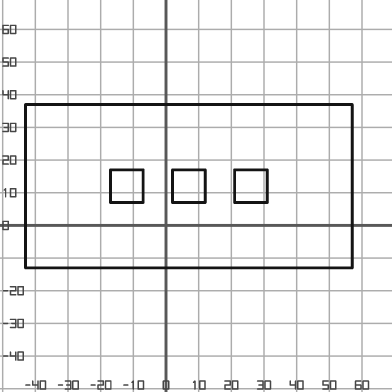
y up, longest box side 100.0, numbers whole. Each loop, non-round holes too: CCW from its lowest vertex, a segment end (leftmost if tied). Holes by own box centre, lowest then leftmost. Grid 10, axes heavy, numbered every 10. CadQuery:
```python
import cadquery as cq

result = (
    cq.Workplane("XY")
    .moveTo(-43.0, -13.0)
    .lineTo(57.0, -13.0)
    .lineTo(57.0, 37.0)
    .lineTo(-43.0, 37.0)
    .close()
    .moveTo(-17.0, 7.0)
    .lineTo(-7.0, 7.0)
    .lineTo(-7.0, 17.0)
    .lineTo(-17.0, 17.0)
    .close()
    .moveTo(2.0, 7.0)
    .lineTo(12.0, 7.0)
    .lineTo(12.0, 17.0)
    .lineTo(2.0, 17.0)
    .close()
    .moveTo(21.0, 7.0)
    .lineTo(31.0, 7.0)
    .lineTo(31.0, 17.0)
    .lineTo(21.0, 17.0)
    .close()
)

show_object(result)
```